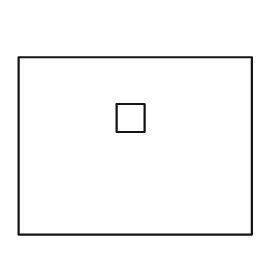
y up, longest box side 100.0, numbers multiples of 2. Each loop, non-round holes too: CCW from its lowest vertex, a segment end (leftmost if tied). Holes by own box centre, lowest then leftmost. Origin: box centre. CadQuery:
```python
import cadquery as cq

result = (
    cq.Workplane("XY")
    .moveTo(-50.0, -38.0)
    .lineTo(50.0, -38.0)
    .lineTo(50.0, 38.0)
    .lineTo(-50.0, 38.0)
    .close()
    .moveTo(-8.0, 6.0)
    .lineTo(4.0, 6.0)
    .lineTo(4.0, 18.0)
    .lineTo(-8.0, 18.0)
    .close()
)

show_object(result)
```